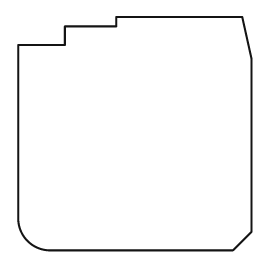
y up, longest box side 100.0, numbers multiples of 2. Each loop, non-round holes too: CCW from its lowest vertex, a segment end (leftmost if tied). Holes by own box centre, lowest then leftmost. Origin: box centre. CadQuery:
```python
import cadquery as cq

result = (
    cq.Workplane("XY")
    .moveTo(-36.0, -50.0)
    .lineTo(42.0, -50.0)
    .lineTo(50.0, -42.0)
    .lineTo(50.0, 32.0)
    .lineTo(46.0, 50.0)
    .lineTo(-8.0, 50.0)
    .lineTo(-8.0, 46.0)
    .lineTo(-30.0, 46.0)
    .lineTo(-30.0, 38.0)
    .lineTo(-50.0, 38.0)
    .lineTo(-50.0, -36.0)
    .threePointArc((-46.0, -46.0), (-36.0, -50.0))
    .close()
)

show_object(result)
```